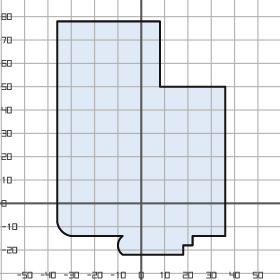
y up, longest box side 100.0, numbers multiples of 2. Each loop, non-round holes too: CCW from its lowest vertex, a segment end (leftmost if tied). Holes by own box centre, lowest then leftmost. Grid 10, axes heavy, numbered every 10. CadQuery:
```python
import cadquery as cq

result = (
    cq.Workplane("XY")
    .moveTo(-8.0, -22.0)
    .lineTo(18.0, -22.0)
    .lineTo(18.0, -18.0)
    .lineTo(22.0, -18.0)
    .lineTo(22.0, -14.0)
    .lineTo(36.0, -14.0)
    .lineTo(36.0, 50.0)
    .lineTo(8.0, 50.0)
    .lineTo(8.0, 78.0)
    .lineTo(-36.0, 78.0)
    .lineTo(-36.0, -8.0)
    .threePointArc((-34.0, -12.0), (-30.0, -14.0))
    .lineTo(-8.0, -14.0)
    .threePointArc((-10.0, -18.0), (-8.0, -22.0))
    .close()
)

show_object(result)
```